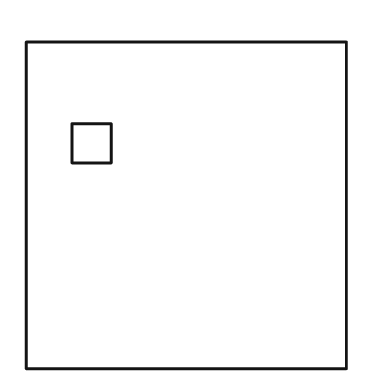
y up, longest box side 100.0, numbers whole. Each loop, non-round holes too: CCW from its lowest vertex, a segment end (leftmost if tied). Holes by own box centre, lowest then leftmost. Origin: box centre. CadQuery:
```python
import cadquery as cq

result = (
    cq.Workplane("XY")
    .moveTo(-49.0, -50.0)
    .lineTo(49.0, -50.0)
    .lineTo(49.0, 50.0)
    .lineTo(-49.0, 50.0)
    .close()
    .moveTo(-35.0, 13.0)
    .lineTo(-23.0, 13.0)
    .lineTo(-23.0, 25.0)
    .lineTo(-35.0, 25.0)
    .close()
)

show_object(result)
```